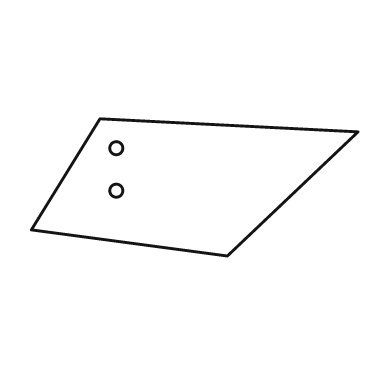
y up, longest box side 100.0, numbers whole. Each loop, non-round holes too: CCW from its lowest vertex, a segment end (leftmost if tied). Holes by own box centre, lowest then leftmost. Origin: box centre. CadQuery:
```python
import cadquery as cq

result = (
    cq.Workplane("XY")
    .moveTo(10.0, -21.0)
    .lineTo(50.0, 17.0)
    .lineTo(-29.0, 21.0)
    .lineTo(-50.0, -13.0)
    .close()
    .moveTo(-24.0, -1.0)
    .circle(2.0)
    .moveTo(-24.0, 12.0)
    .circle(2.0)
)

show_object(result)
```